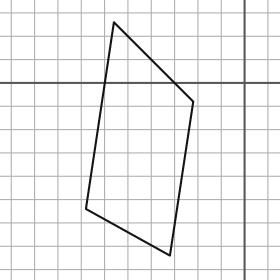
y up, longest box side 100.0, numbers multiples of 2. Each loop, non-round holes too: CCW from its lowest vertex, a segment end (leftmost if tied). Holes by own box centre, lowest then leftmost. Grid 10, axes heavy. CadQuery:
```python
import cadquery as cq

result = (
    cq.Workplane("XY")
    .moveTo(-32.0, -74.0)
    .lineTo(-22.0, -8.0)
    .lineTo(-56.0, 26.0)
    .lineTo(-68.0, -54.0)
    .close()
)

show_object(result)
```